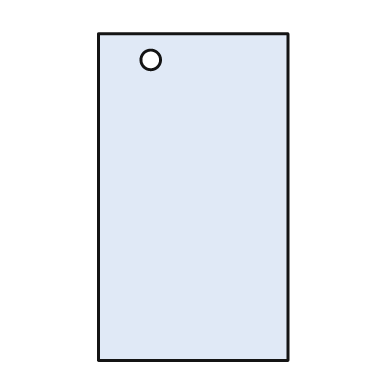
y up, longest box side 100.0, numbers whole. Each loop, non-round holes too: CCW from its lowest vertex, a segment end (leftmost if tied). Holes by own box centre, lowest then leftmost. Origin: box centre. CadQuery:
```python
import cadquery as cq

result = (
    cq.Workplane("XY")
    .moveTo(-29.0, -50.0)
    .lineTo(29.0, -50.0)
    .lineTo(29.0, 50.0)
    .lineTo(-29.0, 50.0)
    .close()
    .moveTo(-13.0, 42.0)
    .circle(3.0)
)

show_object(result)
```